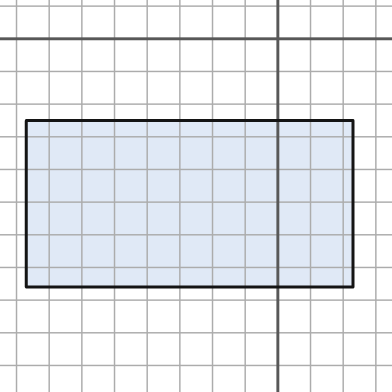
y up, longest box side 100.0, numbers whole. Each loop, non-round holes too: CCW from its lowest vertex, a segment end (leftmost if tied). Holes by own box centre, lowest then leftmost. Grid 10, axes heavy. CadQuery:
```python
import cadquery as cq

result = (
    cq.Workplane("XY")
    .moveTo(-77.0, -76.0)
    .lineTo(23.0, -76.0)
    .lineTo(23.0, -25.0)
    .lineTo(-77.0, -25.0)
    .close()
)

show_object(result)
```